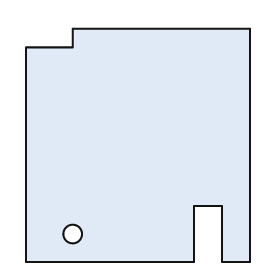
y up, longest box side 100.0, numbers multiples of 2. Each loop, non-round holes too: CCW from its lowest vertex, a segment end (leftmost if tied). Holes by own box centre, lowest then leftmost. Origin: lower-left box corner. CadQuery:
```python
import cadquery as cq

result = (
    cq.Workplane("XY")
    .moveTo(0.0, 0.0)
    .lineTo(72.0, 0.0)
    .lineTo(72.0, 24.0)
    .lineTo(84.0, 24.0)
    .lineTo(84.0, 0.0)
    .lineTo(96.0, 0.0)
    .lineTo(96.0, 100.0)
    .lineTo(20.0, 100.0)
    .lineTo(20.0, 92.0)
    .lineTo(0.0, 92.0)
    .close()
    .moveTo(20.0, 12.0)
    .circle(4.0)
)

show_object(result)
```